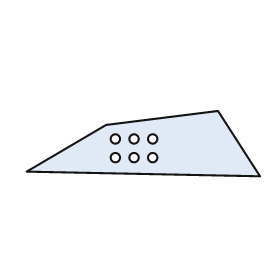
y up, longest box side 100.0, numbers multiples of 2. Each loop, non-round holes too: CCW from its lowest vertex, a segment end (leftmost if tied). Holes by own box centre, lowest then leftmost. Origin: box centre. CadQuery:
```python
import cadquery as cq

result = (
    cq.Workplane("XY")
    .moveTo(50.0, -14.0)
    .lineTo(32.0, 14.0)
    .lineTo(-16.0, 8.0)
    .lineTo(-50.0, -12.0)
    .close()
    .moveTo(-12.0, -6.0)
    .circle(2.0)
    .moveTo(-4.0, -6.0)
    .circle(2.0)
    .moveTo(4.0, -6.0)
    .circle(2.0)
    .moveTo(-12.0, 2.0)
    .circle(2.0)
    .moveTo(-4.0, 2.0)
    .circle(2.0)
    .moveTo(4.0, 2.0)
    .circle(2.0)
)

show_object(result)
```